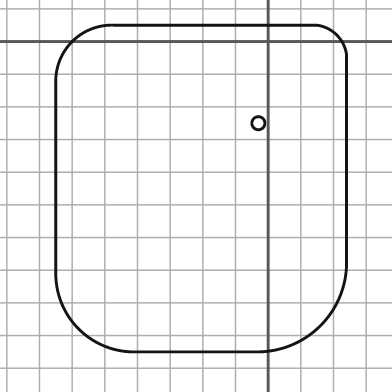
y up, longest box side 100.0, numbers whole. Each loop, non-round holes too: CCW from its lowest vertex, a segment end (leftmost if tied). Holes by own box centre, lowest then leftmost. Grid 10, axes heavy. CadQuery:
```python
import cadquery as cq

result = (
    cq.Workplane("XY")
    .moveTo(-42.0, -95.0)
    .lineTo(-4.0, -95.0)
    .threePointArc((16.0, -87.0), (24.0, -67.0))
    .lineTo(24.0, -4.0)
    .threePointArc((21.0, 2.0), (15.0, 5.0))
    .lineTo(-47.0, 5.0)
    .threePointArc((-60.0, 0.0), (-65.0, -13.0))
    .lineTo(-65.0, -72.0)
    .threePointArc((-58.0, -88.0), (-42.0, -95.0))
    .close()
    .moveTo(-3.0, -25.0)
    .circle(2.0)
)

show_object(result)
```